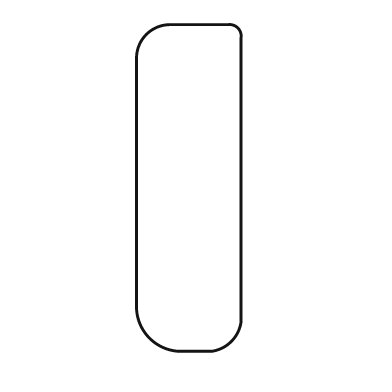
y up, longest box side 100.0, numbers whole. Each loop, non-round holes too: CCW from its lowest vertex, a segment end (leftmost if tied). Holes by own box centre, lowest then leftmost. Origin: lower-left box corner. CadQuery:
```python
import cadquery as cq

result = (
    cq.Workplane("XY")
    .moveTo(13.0, 0.0)
    .lineTo(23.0, 0.0)
    .threePointArc((29.0, 3.0), (32.0, 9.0))
    .lineTo(32.0, 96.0)
    .threePointArc((31.0, 99.0), (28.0, 100.0))
    .lineTo(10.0, 100.0)
    .threePointArc((3.0, 97.0), (0.0, 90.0))
    .lineTo(0.0, 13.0)
    .threePointArc((4.0, 4.0), (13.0, 0.0))
    .close()
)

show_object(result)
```